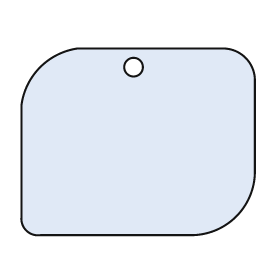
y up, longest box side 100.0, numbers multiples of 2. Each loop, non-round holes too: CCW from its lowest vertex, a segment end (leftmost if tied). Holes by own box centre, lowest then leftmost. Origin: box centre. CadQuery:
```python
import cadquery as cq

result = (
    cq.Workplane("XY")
    .moveTo(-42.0, -40.0)
    .lineTo(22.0, -40.0)
    .threePointArc((42.0, -32.0), (50.0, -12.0))
    .lineTo(50.0, 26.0)
    .threePointArc((46.0, 36.0), (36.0, 40.0))
    .lineTo(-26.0, 40.0)
    .threePointArc((-42.0, 32.0), (-50.0, 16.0))
    .lineTo(-50.0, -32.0)
    .threePointArc((-48.0, -38.0), (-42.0, -40.0))
    .close()
    .moveTo(-2.0, 32.0)
    .circle(4.0)
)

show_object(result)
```